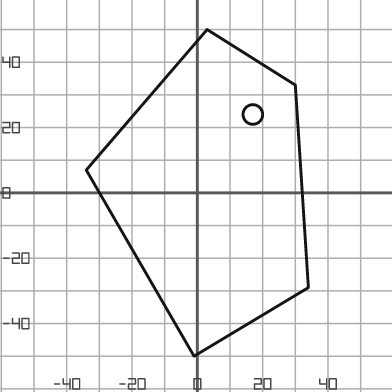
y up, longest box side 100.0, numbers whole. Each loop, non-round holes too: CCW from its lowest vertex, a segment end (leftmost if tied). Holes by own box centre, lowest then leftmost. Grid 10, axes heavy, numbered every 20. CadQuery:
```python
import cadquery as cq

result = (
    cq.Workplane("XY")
    .moveTo(-1.0, -50.0)
    .lineTo(34.0, -29.0)
    .lineTo(30.0, 33.0)
    .lineTo(3.0, 50.0)
    .lineTo(-34.0, 7.0)
    .close()
    .moveTo(17.0, 24.0)
    .circle(3.0)
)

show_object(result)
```